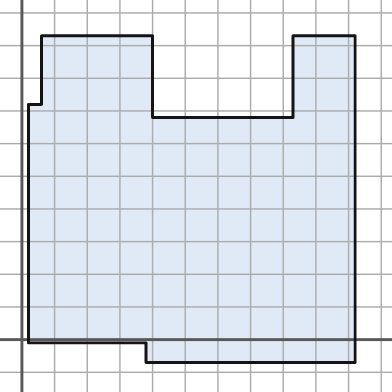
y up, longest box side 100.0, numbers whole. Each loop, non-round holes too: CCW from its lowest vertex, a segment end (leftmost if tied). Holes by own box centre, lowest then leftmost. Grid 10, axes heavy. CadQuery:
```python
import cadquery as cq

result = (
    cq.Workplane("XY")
    .moveTo(38.0, -7.0)
    .lineTo(102.0, -7.0)
    .lineTo(102.0, 93.0)
    .lineTo(83.0, 93.0)
    .lineTo(83.0, 68.0)
    .lineTo(40.0, 68.0)
    .lineTo(40.0, 93.0)
    .lineTo(6.0, 93.0)
    .lineTo(6.0, 72.0)
    .lineTo(2.0, 72.0)
    .lineTo(2.0, -1.0)
    .lineTo(38.0, -1.0)
    .close()
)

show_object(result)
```